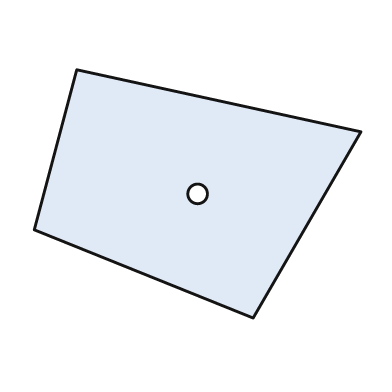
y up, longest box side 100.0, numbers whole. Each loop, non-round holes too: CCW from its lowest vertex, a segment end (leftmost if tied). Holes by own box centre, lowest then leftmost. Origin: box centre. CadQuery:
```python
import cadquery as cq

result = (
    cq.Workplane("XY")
    .moveTo(17.0, -38.0)
    .lineTo(50.0, 19.0)
    .lineTo(-37.0, 38.0)
    .lineTo(-50.0, -11.0)
    .close()
    .moveTo(0.0, 0.0)
    .circle(3.0)
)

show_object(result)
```